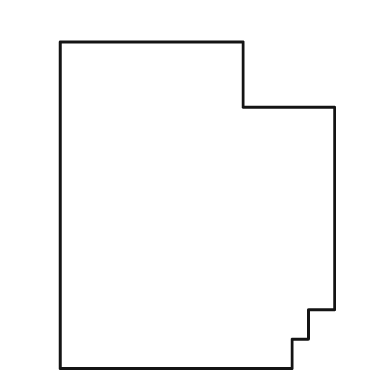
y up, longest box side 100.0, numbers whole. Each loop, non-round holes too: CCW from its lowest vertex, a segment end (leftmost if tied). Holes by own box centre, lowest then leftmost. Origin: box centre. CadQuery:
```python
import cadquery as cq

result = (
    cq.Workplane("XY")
    .moveTo(-42.0, -50.0)
    .lineTo(29.0, -50.0)
    .lineTo(29.0, -41.0)
    .lineTo(34.0, -41.0)
    .lineTo(34.0, -32.0)
    .lineTo(42.0, -32.0)
    .lineTo(42.0, 30.0)
    .lineTo(14.0, 30.0)
    .lineTo(14.0, 50.0)
    .lineTo(-42.0, 50.0)
    .close()
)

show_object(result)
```